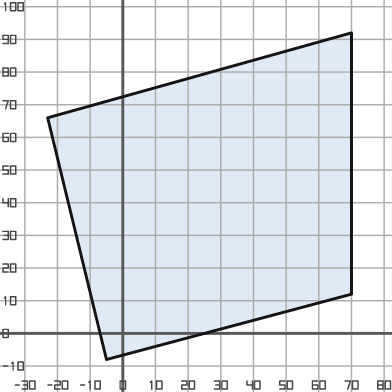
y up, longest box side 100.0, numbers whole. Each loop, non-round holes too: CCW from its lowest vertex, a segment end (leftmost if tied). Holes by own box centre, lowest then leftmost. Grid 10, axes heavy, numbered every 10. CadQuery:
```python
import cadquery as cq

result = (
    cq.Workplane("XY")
    .moveTo(-5.0, -8.0)
    .lineTo(70.0, 12.0)
    .lineTo(70.0, 92.0)
    .lineTo(-23.0, 66.0)
    .close()
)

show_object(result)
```